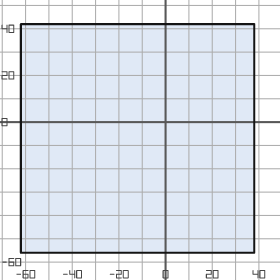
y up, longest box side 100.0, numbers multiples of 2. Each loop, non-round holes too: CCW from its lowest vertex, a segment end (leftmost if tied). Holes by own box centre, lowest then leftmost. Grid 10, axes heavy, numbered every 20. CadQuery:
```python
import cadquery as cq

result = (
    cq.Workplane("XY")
    .moveTo(-62.0, -56.0)
    .lineTo(38.0, -56.0)
    .lineTo(38.0, 42.0)
    .lineTo(-62.0, 42.0)
    .close()
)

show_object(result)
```